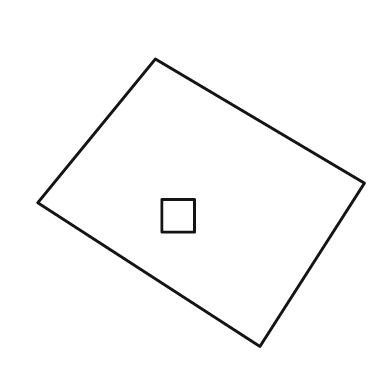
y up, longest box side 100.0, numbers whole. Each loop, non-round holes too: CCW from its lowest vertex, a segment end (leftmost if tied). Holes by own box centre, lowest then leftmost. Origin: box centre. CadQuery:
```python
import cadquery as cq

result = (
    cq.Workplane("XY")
    .moveTo(18.0, -44.0)
    .lineTo(50.0, 6.0)
    .lineTo(-14.0, 44.0)
    .lineTo(-50.0, 0.0)
    .close()
    .moveTo(-12.0, -9.0)
    .lineTo(-2.0, -9.0)
    .lineTo(-2.0, 1.0)
    .lineTo(-12.0, 1.0)
    .close()
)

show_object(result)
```